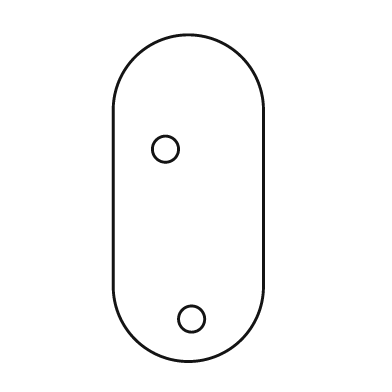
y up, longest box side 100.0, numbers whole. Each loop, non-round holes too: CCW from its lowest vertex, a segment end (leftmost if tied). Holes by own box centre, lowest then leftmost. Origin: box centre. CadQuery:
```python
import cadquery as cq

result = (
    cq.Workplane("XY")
    .moveTo(-23.0, -27.0)
    .threePointArc((0.0, -50.0), (23.0, -27.0))
    .lineTo(23.0, 27.0)
    .threePointArc((0.0, 50.0), (-23.0, 27.0))
    .close()
    .moveTo(1.0, -37.0)
    .circle(4.0)
    .moveTo(-7.0, 15.0)
    .circle(4.0)
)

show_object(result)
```